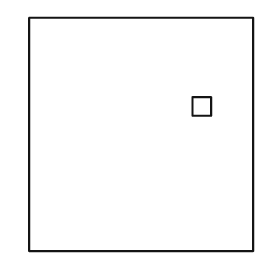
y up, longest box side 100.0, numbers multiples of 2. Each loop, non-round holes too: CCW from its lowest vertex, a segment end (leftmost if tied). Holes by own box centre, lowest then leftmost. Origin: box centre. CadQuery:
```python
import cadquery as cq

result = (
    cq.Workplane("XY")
    .moveTo(-48.0, -50.0)
    .lineTo(48.0, -50.0)
    .lineTo(48.0, 50.0)
    .lineTo(-48.0, 50.0)
    .close()
    .moveTo(22.0, 8.0)
    .lineTo(30.0, 8.0)
    .lineTo(30.0, 16.0)
    .lineTo(22.0, 16.0)
    .close()
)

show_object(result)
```